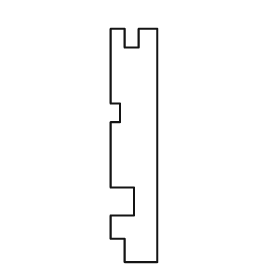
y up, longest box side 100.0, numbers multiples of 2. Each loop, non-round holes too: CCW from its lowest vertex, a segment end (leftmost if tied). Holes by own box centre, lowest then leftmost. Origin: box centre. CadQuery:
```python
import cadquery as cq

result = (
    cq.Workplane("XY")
    .moveTo(-4.0, -50.0)
    .lineTo(10.0, -50.0)
    .lineTo(10.0, 50.0)
    .lineTo(2.0, 50.0)
    .lineTo(2.0, 42.0)
    .lineTo(-4.0, 42.0)
    .lineTo(-4.0, 50.0)
    .lineTo(-10.0, 50.0)
    .lineTo(-10.0, 18.0)
    .lineTo(-6.0, 18.0)
    .lineTo(-6.0, 10.0)
    .lineTo(-10.0, 10.0)
    .lineTo(-10.0, -18.0)
    .lineTo(0.0, -18.0)
    .lineTo(0.0, -30.0)
    .lineTo(-10.0, -30.0)
    .lineTo(-10.0, -40.0)
    .lineTo(-4.0, -40.0)
    .close()
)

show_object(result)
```